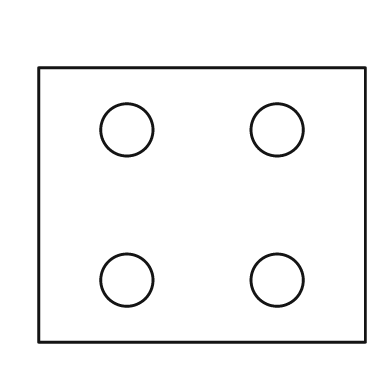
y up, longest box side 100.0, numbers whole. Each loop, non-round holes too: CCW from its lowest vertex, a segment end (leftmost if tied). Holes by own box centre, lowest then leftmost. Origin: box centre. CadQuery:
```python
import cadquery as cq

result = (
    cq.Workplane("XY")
    .moveTo(-50.0, -42.0)
    .lineTo(50.0, -42.0)
    .lineTo(50.0, 42.0)
    .lineTo(-50.0, 42.0)
    .close()
    .moveTo(-23.0, -23.0)
    .circle(8.0)
    .moveTo(23.0, -23.0)
    .circle(8.0)
    .moveTo(-23.0, 23.0)
    .circle(8.0)
    .moveTo(23.0, 23.0)
    .circle(8.0)
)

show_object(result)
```